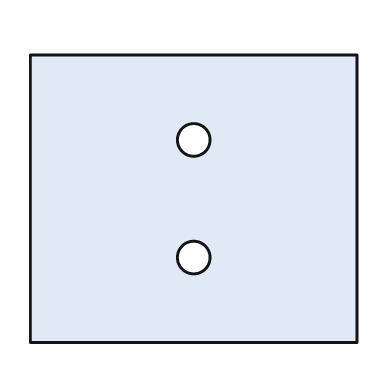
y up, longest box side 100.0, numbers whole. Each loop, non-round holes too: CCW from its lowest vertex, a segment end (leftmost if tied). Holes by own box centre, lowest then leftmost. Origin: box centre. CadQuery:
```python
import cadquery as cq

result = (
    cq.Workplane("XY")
    .moveTo(-50.0, -44.0)
    .lineTo(50.0, -44.0)
    .lineTo(50.0, 44.0)
    .lineTo(-50.0, 44.0)
    .close()
    .moveTo(0.0, -18.0)
    .circle(5.0)
    .moveTo(0.0, 18.0)
    .circle(5.0)
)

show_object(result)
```